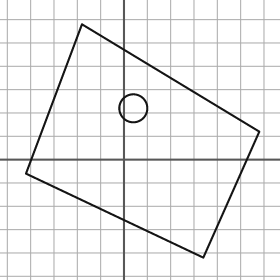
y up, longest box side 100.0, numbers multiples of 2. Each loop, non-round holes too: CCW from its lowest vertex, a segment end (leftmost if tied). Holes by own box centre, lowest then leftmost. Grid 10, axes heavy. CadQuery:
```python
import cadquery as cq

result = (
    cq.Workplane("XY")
    .moveTo(34.0, -42.0)
    .lineTo(58.0, 12.0)
    .lineTo(-18.0, 58.0)
    .lineTo(-42.0, -6.0)
    .close()
    .moveTo(4.0, 22.0)
    .circle(6.0)
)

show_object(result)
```